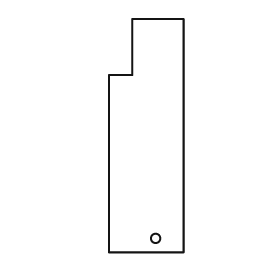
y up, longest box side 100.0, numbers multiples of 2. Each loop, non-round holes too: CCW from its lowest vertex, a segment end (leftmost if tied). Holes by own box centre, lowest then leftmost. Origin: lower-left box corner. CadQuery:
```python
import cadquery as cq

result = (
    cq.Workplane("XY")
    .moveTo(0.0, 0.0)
    .lineTo(32.0, 0.0)
    .lineTo(32.0, 100.0)
    .lineTo(10.0, 100.0)
    .lineTo(10.0, 76.0)
    .lineTo(0.0, 76.0)
    .close()
    .moveTo(20.0, 6.0)
    .circle(2.0)
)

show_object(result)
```